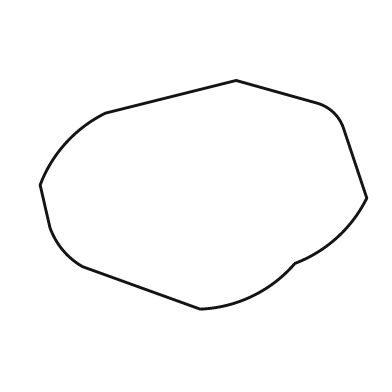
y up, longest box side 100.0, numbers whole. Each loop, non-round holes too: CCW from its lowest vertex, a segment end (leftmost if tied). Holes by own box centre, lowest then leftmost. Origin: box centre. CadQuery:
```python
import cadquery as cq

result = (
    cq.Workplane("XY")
    .moveTo(-1.0, -35.0)
    .threePointArc((15.0, -31.0), (28.0, -21.0))
    .threePointArc((41.0, -13.0), (50.0, -1.0))
    .lineTo(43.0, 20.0)
    .threePointArc((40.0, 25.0), (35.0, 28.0))
    .lineTo(10.0, 35.0)
    .lineTo(-30.0, 25.0)
    .threePointArc((-42.0, 16.0), (-50.0, 3.0))
    .lineTo(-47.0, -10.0)
    .threePointArc((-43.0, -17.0), (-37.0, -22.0))
    .close()
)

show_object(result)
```